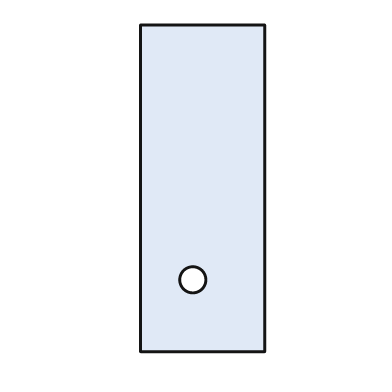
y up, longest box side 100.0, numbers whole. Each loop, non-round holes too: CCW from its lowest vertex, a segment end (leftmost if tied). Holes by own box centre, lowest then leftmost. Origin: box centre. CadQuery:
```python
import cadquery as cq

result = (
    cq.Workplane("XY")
    .moveTo(-19.0, -50.0)
    .lineTo(19.0, -50.0)
    .lineTo(19.0, 50.0)
    .lineTo(-19.0, 50.0)
    .close()
    .moveTo(-3.0, -28.0)
    .circle(4.0)
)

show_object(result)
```